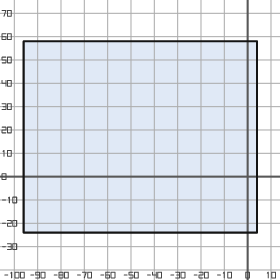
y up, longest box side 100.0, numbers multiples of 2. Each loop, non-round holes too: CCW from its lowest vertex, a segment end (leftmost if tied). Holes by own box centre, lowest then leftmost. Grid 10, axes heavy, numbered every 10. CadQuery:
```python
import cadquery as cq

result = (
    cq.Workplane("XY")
    .moveTo(-96.0, -24.0)
    .lineTo(4.0, -24.0)
    .lineTo(4.0, 58.0)
    .lineTo(-96.0, 58.0)
    .close()
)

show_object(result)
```